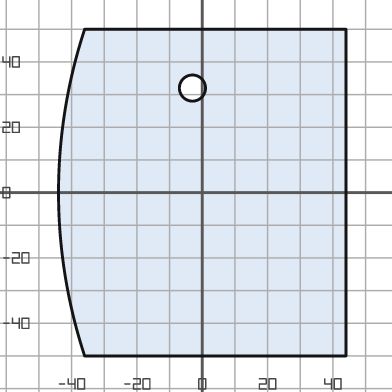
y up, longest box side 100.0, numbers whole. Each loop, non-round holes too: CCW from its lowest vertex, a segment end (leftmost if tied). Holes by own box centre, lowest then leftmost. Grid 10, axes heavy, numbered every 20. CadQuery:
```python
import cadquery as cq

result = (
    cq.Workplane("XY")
    .moveTo(-36.0, -50.0)
    .lineTo(44.0, -50.0)
    .lineTo(44.0, 50.0)
    .lineTo(-36.0, 50.0)
    .threePointArc((-44.0, 0.0), (-36.0, -50.0))
    .close()
    .moveTo(-3.0, 32.0)
    .circle(4.0)
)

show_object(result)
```